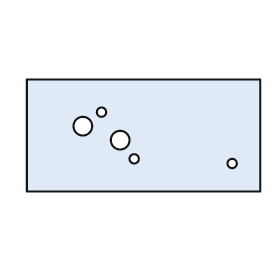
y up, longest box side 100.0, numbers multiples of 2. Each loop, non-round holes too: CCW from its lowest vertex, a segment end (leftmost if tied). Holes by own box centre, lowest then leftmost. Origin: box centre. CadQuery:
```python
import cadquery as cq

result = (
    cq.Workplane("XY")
    .moveTo(-50.0, -24.0)
    .lineTo(50.0, -24.0)
    .lineTo(50.0, 24.0)
    .lineTo(-50.0, 24.0)
    .close()
    .moveTo(38.0, -12.0)
    .circle(2.0)
    .moveTo(-4.0, -10.0)
    .circle(2.0)
    .moveTo(-10.0, -2.0)
    .circle(4.0)
    .moveTo(-26.0, 4.0)
    .circle(4.0)
    .moveTo(-18.0, 10.0)
    .circle(2.0)
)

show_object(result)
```